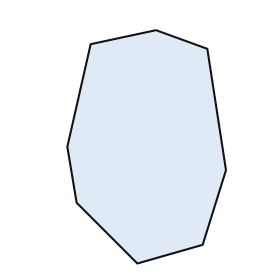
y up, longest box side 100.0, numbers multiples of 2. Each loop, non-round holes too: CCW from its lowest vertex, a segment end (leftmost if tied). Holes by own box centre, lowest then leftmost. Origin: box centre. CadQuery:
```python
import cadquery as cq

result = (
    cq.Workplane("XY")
    .moveTo(-4.0, -50.0)
    .lineTo(24.0, -42.0)
    .lineTo(34.0, -10.0)
    .lineTo(26.0, 42.0)
    .lineTo(4.0, 50.0)
    .lineTo(-24.0, 44.0)
    .lineTo(-34.0, 0.0)
    .lineTo(-30.0, -24.0)
    .close()
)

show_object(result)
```